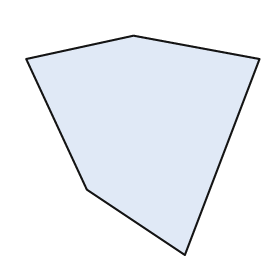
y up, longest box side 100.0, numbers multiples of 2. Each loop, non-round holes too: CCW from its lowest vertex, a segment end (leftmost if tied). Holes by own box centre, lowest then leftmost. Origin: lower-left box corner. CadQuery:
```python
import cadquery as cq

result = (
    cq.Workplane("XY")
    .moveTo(68.0, 0.0)
    .lineTo(100.0, 84.0)
    .lineTo(46.0, 94.0)
    .lineTo(0.0, 84.0)
    .lineTo(26.0, 28.0)
    .close()
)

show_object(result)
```